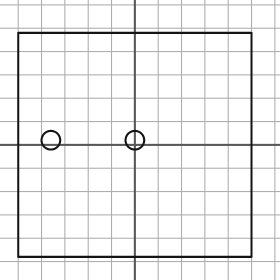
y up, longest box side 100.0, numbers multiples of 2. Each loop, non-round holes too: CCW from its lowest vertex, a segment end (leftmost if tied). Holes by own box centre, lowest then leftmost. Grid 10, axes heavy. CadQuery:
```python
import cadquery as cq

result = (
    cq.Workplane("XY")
    .moveTo(-50.0, -48.0)
    .lineTo(50.0, -48.0)
    .lineTo(50.0, 48.0)
    .lineTo(-50.0, 48.0)
    .close()
    .moveTo(-36.0, 2.0)
    .circle(4.0)
    .moveTo(0.0, 2.0)
    .circle(4.0)
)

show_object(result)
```